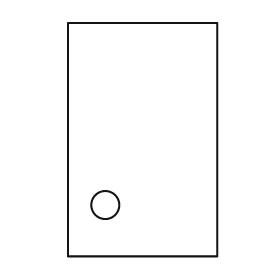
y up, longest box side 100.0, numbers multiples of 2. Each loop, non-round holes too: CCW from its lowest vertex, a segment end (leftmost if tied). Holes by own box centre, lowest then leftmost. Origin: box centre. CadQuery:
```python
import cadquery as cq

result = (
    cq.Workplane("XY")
    .moveTo(-32.0, -50.0)
    .lineTo(32.0, -50.0)
    .lineTo(32.0, 50.0)
    .lineTo(-32.0, 50.0)
    .close()
    .moveTo(-16.0, -28.0)
    .circle(6.0)
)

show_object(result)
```